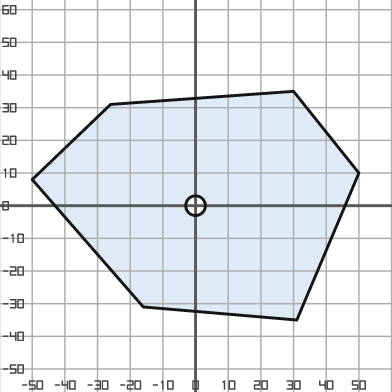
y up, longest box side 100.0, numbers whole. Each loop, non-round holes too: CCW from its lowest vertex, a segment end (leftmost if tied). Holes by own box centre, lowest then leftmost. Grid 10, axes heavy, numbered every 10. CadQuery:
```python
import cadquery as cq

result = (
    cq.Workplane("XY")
    .moveTo(31.0, -35.0)
    .lineTo(50.0, 10.0)
    .lineTo(30.0, 35.0)
    .lineTo(-26.0, 31.0)
    .lineTo(-50.0, 8.0)
    .lineTo(-16.0, -31.0)
    .close()
    .moveTo(0.0, 0.0)
    .circle(3.0)
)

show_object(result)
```